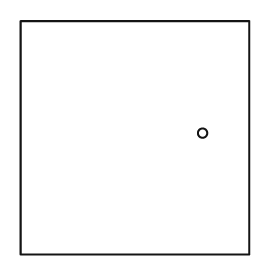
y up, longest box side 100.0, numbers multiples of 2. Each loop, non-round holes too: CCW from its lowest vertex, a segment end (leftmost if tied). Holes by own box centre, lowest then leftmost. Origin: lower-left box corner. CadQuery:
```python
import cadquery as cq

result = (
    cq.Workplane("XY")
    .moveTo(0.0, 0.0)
    .lineTo(98.0, 0.0)
    .lineTo(98.0, 100.0)
    .lineTo(0.0, 100.0)
    .close()
    .moveTo(78.0, 52.0)
    .circle(2.0)
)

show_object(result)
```